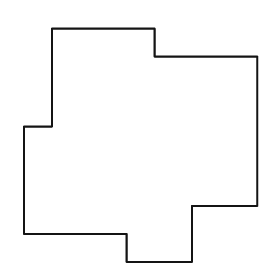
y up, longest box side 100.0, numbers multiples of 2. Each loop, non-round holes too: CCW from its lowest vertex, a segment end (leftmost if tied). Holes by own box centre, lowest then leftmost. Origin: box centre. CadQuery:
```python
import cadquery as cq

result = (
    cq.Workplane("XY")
    .moveTo(-6.0, -50.0)
    .lineTo(22.0, -50.0)
    .lineTo(22.0, -26.0)
    .lineTo(50.0, -26.0)
    .lineTo(50.0, 38.0)
    .lineTo(6.0, 38.0)
    .lineTo(6.0, 50.0)
    .lineTo(-38.0, 50.0)
    .lineTo(-38.0, 8.0)
    .lineTo(-50.0, 8.0)
    .lineTo(-50.0, -38.0)
    .lineTo(-6.0, -38.0)
    .close()
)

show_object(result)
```